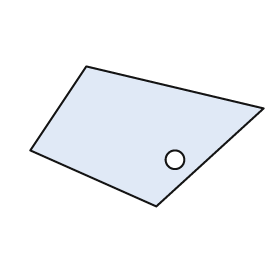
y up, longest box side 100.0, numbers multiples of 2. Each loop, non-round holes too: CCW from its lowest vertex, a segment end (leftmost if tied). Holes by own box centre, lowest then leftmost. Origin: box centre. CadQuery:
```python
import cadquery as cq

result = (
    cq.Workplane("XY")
    .moveTo(4.0, -30.0)
    .lineTo(50.0, 12.0)
    .lineTo(-26.0, 30.0)
    .lineTo(-50.0, -6.0)
    .close()
    .moveTo(12.0, -10.0)
    .circle(4.0)
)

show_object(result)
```